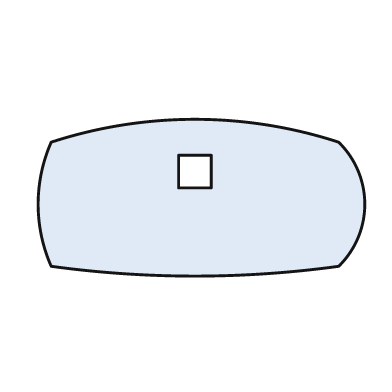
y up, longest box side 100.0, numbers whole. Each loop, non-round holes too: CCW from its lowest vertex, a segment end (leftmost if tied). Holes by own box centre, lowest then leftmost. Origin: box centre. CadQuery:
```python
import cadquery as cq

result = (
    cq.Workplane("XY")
    .moveTo(-46.0, -21.0)
    .threePointArc((-2.0, -24.0), (42.0, -21.0))
    .threePointArc((50.0, -2.0), (42.0, 17.0))
    .threePointArc((-2.0, 24.0), (-46.0, 17.0))
    .threePointArc((-50.0, -2.0), (-46.0, -21.0))
    .close()
    .moveTo(-7.0, 3.0)
    .lineTo(3.0, 3.0)
    .lineTo(3.0, 13.0)
    .lineTo(-7.0, 13.0)
    .close()
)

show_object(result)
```